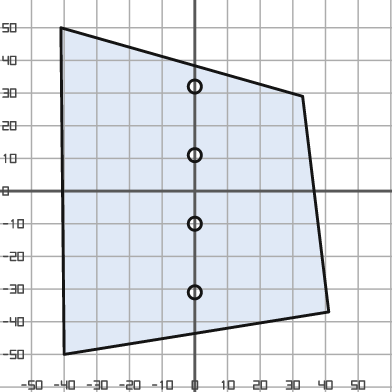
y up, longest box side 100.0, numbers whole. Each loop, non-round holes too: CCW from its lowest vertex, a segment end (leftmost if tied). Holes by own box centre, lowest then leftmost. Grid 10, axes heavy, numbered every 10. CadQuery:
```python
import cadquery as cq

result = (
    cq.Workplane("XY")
    .moveTo(-40.0, -50.0)
    .lineTo(41.0, -37.0)
    .lineTo(33.0, 29.0)
    .lineTo(-41.0, 50.0)
    .close()
    .moveTo(0.0, -31.0)
    .circle(2.0)
    .moveTo(0.0, -10.0)
    .circle(2.0)
    .moveTo(0.0, 11.0)
    .circle(2.0)
    .moveTo(0.0, 32.0)
    .circle(2.0)
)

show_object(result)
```